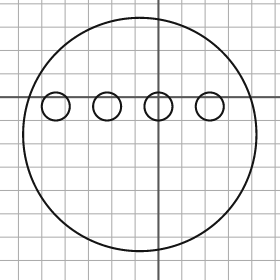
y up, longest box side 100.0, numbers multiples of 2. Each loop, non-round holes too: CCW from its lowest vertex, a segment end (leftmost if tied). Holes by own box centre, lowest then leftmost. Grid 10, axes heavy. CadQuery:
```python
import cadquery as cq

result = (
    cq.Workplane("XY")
    .moveTo(-8.0, -16.0)
    .circle(50.0)
    .moveTo(-44.0, -4.0)
    .circle(6.0)
    .moveTo(-22.0, -4.0)
    .circle(6.0)
    .moveTo(0.0, -4.0)
    .circle(6.0)
    .moveTo(22.0, -4.0)
    .circle(6.0)
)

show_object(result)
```